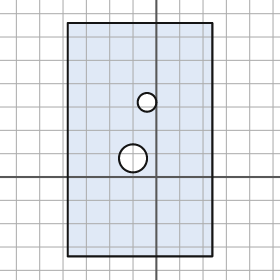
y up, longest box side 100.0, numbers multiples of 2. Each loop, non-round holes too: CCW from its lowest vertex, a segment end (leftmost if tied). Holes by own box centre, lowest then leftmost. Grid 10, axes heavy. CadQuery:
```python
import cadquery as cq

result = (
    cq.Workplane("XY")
    .moveTo(-38.0, -34.0)
    .lineTo(24.0, -34.0)
    .lineTo(24.0, 66.0)
    .lineTo(-38.0, 66.0)
    .close()
    .moveTo(-10.0, 8.0)
    .circle(6.0)
    .moveTo(-4.0, 32.0)
    .circle(4.0)
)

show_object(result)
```